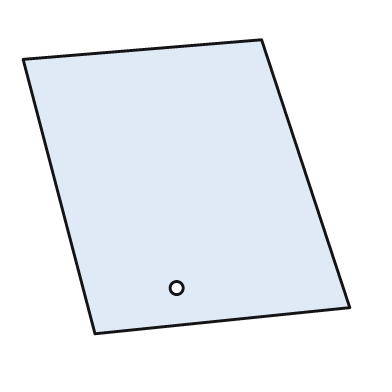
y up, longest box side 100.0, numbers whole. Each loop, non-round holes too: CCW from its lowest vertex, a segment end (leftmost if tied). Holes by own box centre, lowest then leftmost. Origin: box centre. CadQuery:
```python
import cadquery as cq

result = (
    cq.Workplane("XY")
    .moveTo(-28.0, -45.0)
    .lineTo(50.0, -37.0)
    .lineTo(23.0, 45.0)
    .lineTo(-50.0, 39.0)
    .close()
    .moveTo(-3.0, -31.0)
    .circle(2.0)
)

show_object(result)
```